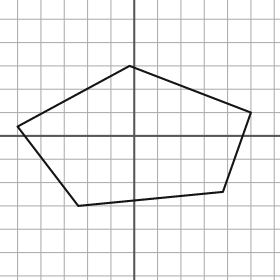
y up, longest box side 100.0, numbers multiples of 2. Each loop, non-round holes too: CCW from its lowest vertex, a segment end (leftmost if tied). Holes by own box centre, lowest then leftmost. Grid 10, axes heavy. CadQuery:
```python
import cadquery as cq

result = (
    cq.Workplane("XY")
    .moveTo(-24.0, -30.0)
    .lineTo(38.0, -24.0)
    .lineTo(50.0, 10.0)
    .lineTo(-2.0, 30.0)
    .lineTo(-50.0, 4.0)
    .close()
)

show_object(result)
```